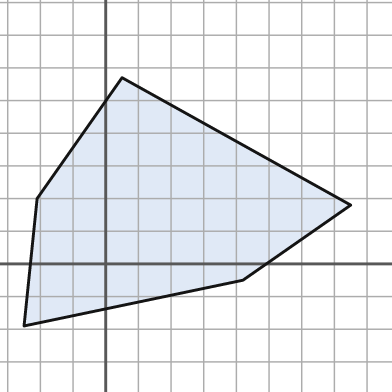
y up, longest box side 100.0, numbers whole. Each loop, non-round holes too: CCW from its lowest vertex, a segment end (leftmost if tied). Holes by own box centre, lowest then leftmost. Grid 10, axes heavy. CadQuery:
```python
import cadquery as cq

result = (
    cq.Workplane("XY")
    .moveTo(-25.0, -19.0)
    .lineTo(42.0, -5.0)
    .lineTo(75.0, 18.0)
    .lineTo(5.0, 57.0)
    .lineTo(-21.0, 20.0)
    .close()
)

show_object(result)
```